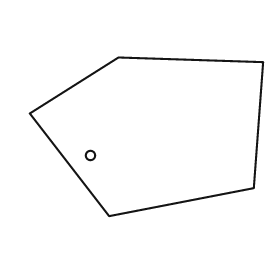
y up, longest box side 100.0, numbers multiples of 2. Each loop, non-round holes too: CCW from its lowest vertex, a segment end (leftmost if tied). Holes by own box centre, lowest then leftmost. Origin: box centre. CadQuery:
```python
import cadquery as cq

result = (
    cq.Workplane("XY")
    .moveTo(-16.0, -34.0)
    .lineTo(46.0, -22.0)
    .lineTo(50.0, 32.0)
    .lineTo(-12.0, 34.0)
    .lineTo(-50.0, 10.0)
    .close()
    .moveTo(-24.0, -8.0)
    .circle(2.0)
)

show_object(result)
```